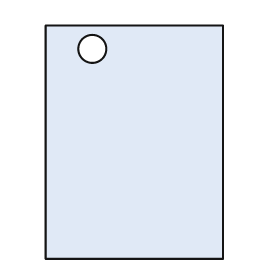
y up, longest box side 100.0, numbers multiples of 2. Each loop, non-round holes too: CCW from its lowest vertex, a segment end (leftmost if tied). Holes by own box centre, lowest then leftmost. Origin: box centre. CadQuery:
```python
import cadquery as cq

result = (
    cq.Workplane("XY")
    .moveTo(-38.0, -50.0)
    .lineTo(38.0, -50.0)
    .lineTo(38.0, 50.0)
    .lineTo(-38.0, 50.0)
    .close()
    .moveTo(-18.0, 40.0)
    .circle(6.0)
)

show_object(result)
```